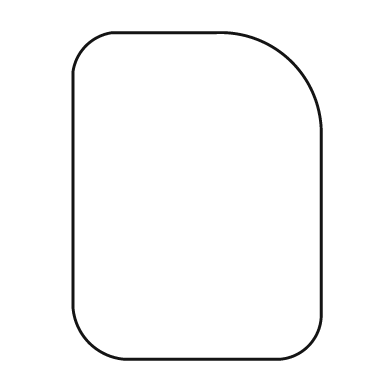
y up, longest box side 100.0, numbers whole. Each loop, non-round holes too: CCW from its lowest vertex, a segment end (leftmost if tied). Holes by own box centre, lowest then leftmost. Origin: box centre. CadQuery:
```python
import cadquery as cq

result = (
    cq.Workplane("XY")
    .moveTo(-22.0, -50.0)
    .lineTo(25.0, -50.0)
    .threePointArc((34.0, -46.0), (38.0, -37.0))
    .lineTo(38.0, 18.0)
    .threePointArc((29.0, 41.0), (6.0, 50.0))
    .lineTo(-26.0, 50.0)
    .threePointArc((-34.0, 46.0), (-38.0, 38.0))
    .lineTo(-38.0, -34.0)
    .threePointArc((-33.0, -45.0), (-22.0, -50.0))
    .close()
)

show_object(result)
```